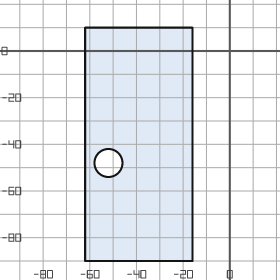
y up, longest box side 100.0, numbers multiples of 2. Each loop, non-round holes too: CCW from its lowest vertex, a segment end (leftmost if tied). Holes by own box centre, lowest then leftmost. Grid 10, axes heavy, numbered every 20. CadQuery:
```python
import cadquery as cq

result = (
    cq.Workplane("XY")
    .moveTo(-62.0, -90.0)
    .lineTo(-16.0, -90.0)
    .lineTo(-16.0, 10.0)
    .lineTo(-62.0, 10.0)
    .close()
    .moveTo(-52.0, -48.0)
    .circle(6.0)
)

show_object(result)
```